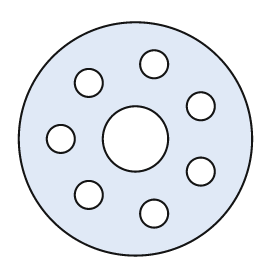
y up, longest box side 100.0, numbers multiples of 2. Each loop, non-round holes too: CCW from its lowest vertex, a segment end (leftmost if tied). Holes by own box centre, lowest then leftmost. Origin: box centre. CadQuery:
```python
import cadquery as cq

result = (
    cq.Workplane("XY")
    .moveTo(0.0, 0.0)
    .circle(50.0)
    .moveTo(8.0, -32.0)
    .circle(6.0)
    .moveTo(-20.0, -24.0)
    .circle(6.0)
    .moveTo(28.0, -14.0)
    .circle(6.0)
    .moveTo(-32.0, 0.0)
    .circle(6.0)
    .moveTo(0.0, 0.0)
    .circle(14.0)
    .moveTo(28.0, 14.0)
    .circle(6.0)
    .moveTo(-20.0, 24.0)
    .circle(6.0)
    .moveTo(8.0, 32.0)
    .circle(6.0)
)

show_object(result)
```